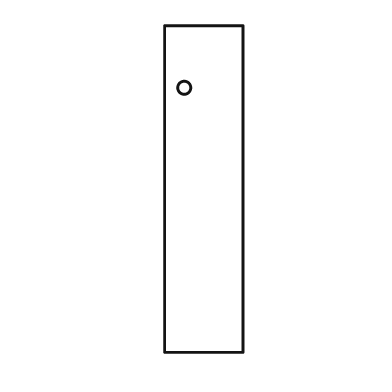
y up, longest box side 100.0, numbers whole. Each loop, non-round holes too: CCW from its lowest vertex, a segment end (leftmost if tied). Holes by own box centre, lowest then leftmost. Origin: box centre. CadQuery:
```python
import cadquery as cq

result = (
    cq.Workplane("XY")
    .moveTo(-12.0, -50.0)
    .lineTo(12.0, -50.0)
    .lineTo(12.0, 50.0)
    .lineTo(-12.0, 50.0)
    .close()
    .moveTo(-6.0, 31.0)
    .circle(2.0)
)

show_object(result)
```